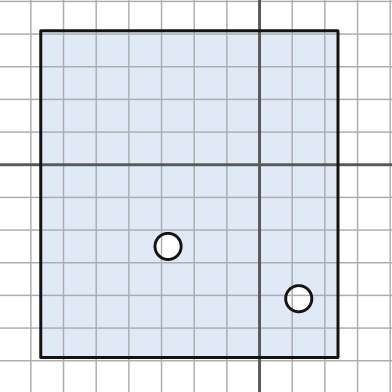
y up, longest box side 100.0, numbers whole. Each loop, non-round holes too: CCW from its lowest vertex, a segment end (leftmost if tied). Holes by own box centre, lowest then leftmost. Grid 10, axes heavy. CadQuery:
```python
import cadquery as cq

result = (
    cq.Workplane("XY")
    .moveTo(-67.0, -59.0)
    .lineTo(24.0, -59.0)
    .lineTo(24.0, 41.0)
    .lineTo(-67.0, 41.0)
    .close()
    .moveTo(12.0, -41.0)
    .circle(4.0)
    .moveTo(-28.0, -25.0)
    .circle(4.0)
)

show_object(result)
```